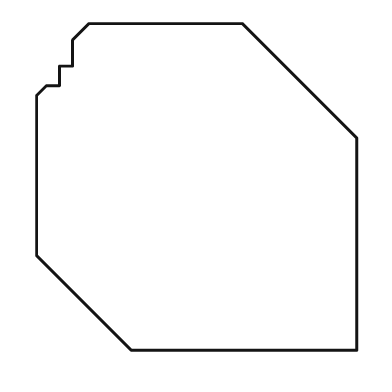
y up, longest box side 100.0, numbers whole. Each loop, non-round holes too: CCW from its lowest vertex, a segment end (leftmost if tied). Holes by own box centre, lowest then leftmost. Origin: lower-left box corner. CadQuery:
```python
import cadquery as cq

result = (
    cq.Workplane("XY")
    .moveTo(29.0, 0.0)
    .lineTo(98.0, 0.0)
    .lineTo(98.0, 65.0)
    .lineTo(63.0, 100.0)
    .lineTo(16.0, 100.0)
    .lineTo(11.0, 95.0)
    .lineTo(11.0, 87.0)
    .lineTo(7.0, 87.0)
    .lineTo(7.0, 81.0)
    .lineTo(3.0, 81.0)
    .lineTo(0.0, 78.0)
    .lineTo(0.0, 29.0)
    .close()
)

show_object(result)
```